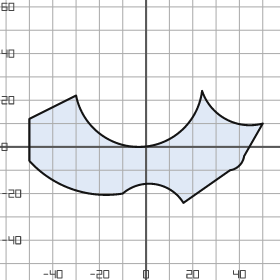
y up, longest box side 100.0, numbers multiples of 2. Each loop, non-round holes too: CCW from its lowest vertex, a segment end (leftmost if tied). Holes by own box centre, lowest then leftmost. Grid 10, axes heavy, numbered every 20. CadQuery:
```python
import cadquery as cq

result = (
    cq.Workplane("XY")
    .moveTo(16.0, -24.0)
    .lineTo(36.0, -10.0)
    .threePointArc((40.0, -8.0), (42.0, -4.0))
    .lineTo(50.0, 10.0)
    .threePointArc((34.0, 12.0), (24.0, 24.0))
    .threePointArc((-2.0, 0.0), (-30.0, 22.0))
    .lineTo(-50.0, 12.0)
    .lineTo(-50.0, -6.0)
    .threePointArc((-32.0, -18.0), (-10.0, -20.0))
    .threePointArc((4.0, -16.0), (16.0, -24.0))
    .close()
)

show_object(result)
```